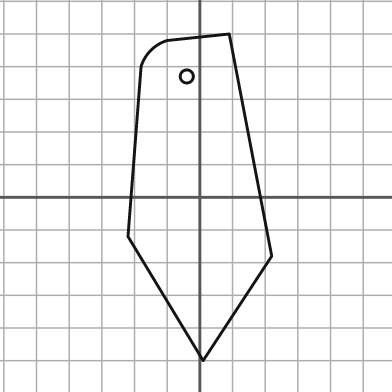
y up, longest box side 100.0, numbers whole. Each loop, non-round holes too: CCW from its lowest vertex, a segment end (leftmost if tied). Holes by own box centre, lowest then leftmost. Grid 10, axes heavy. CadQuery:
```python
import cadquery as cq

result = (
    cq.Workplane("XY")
    .moveTo(1.0, -50.0)
    .lineTo(22.0, -18.0)
    .lineTo(9.0, 50.0)
    .lineTo(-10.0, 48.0)
    .threePointArc((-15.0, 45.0), (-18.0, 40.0))
    .lineTo(-22.0, -12.0)
    .close()
    .moveTo(-4.0, 37.0)
    .circle(2.0)
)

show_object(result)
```